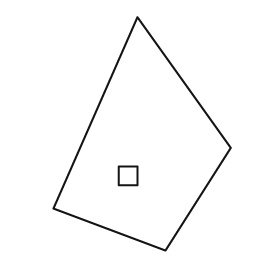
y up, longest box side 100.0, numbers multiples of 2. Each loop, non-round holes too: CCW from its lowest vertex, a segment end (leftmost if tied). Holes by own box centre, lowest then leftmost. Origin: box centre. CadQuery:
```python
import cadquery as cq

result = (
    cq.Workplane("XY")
    .moveTo(10.0, -50.0)
    .lineTo(38.0, -6.0)
    .lineTo(-2.0, 50.0)
    .lineTo(-38.0, -32.0)
    .close()
    .moveTo(-10.0, -22.0)
    .lineTo(-2.0, -22.0)
    .lineTo(-2.0, -14.0)
    .lineTo(-10.0, -14.0)
    .close()
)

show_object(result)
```